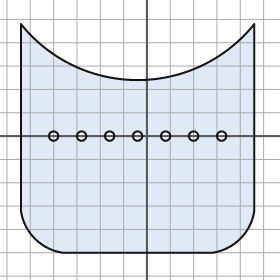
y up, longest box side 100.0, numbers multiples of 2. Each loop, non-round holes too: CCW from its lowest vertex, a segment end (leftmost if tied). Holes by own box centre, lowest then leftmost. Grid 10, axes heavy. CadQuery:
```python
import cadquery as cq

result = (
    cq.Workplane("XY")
    .moveTo(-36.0, -50.0)
    .lineTo(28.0, -50.0)
    .threePointArc((40.0, -44.0), (46.0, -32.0))
    .lineTo(46.0, 48.0)
    .threePointArc((-4.0, 24.0), (-54.0, 48.0))
    .lineTo(-54.0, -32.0)
    .threePointArc((-48.0, -44.0), (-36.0, -50.0))
    .close()
    .moveTo(-40.0, 0.0)
    .circle(2.0)
    .moveTo(-28.0, 0.0)
    .circle(2.0)
    .moveTo(-16.0, 0.0)
    .circle(2.0)
    .moveTo(-4.0, 0.0)
    .circle(2.0)
    .moveTo(8.0, 0.0)
    .circle(2.0)
    .moveTo(20.0, 0.0)
    .circle(2.0)
    .moveTo(32.0, 0.0)
    .circle(2.0)
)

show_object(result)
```